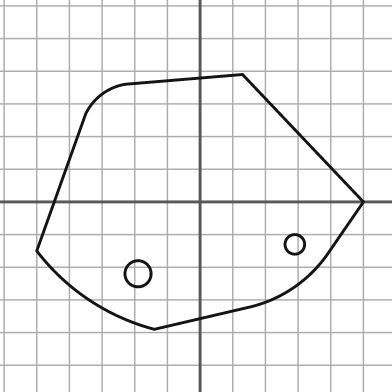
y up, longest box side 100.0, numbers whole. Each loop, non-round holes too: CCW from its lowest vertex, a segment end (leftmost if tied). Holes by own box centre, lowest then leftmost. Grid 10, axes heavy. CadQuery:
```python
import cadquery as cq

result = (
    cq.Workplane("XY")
    .moveTo(-14.0, -39.0)
    .lineTo(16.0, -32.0)
    .threePointArc((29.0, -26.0), (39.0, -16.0))
    .lineTo(50.0, 0.0)
    .lineTo(13.0, 39.0)
    .lineTo(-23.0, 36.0)
    .threePointArc((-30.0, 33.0), (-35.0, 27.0))
    .lineTo(-50.0, -15.0)
    .threePointArc((-34.0, -30.0), (-14.0, -39.0))
    .close()
    .moveTo(-19.0, -22.0)
    .circle(4.0)
    .moveTo(29.0, -13.0)
    .circle(3.0)
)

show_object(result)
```